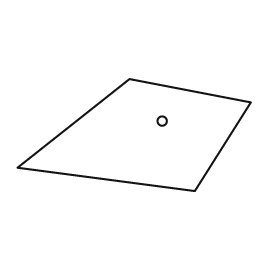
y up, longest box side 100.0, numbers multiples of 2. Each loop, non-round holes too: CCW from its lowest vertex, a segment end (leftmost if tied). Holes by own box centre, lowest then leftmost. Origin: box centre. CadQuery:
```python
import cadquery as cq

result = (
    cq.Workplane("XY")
    .moveTo(26.0, -24.0)
    .lineTo(50.0, 14.0)
    .lineTo(-2.0, 24.0)
    .lineTo(-50.0, -14.0)
    .close()
    .moveTo(12.0, 6.0)
    .circle(2.0)
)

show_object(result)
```